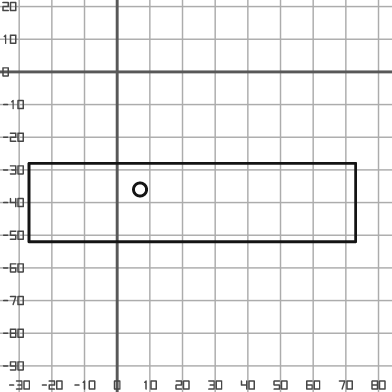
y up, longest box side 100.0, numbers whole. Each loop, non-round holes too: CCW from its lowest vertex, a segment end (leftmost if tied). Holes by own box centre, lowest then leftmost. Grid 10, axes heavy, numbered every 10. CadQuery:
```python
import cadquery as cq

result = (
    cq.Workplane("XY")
    .moveTo(-27.0, -52.0)
    .lineTo(73.0, -52.0)
    .lineTo(73.0, -28.0)
    .lineTo(-27.0, -28.0)
    .close()
    .moveTo(7.0, -36.0)
    .circle(2.0)
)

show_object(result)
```